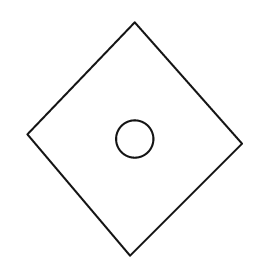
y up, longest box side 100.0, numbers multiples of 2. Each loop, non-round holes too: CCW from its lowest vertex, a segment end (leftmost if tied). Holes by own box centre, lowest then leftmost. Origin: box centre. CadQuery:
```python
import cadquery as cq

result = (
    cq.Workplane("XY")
    .moveTo(-2.0, -50.0)
    .lineTo(46.0, -2.0)
    .lineTo(0.0, 50.0)
    .lineTo(-46.0, 2.0)
    .close()
    .moveTo(0.0, 0.0)
    .circle(8.0)
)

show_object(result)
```